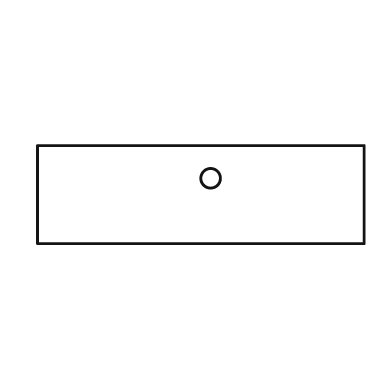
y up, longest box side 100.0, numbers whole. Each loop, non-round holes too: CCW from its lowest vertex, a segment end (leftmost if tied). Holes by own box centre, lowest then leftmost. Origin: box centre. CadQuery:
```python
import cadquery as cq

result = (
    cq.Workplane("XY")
    .moveTo(-50.0, -15.0)
    .lineTo(50.0, -15.0)
    .lineTo(50.0, 15.0)
    .lineTo(-50.0, 15.0)
    .close()
    .moveTo(3.0, 5.0)
    .circle(3.0)
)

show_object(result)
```